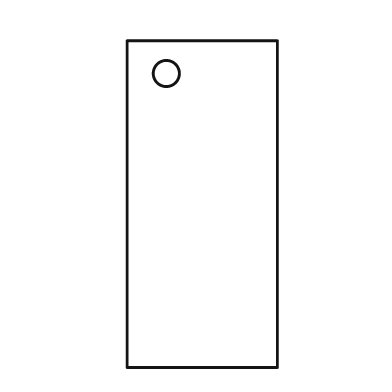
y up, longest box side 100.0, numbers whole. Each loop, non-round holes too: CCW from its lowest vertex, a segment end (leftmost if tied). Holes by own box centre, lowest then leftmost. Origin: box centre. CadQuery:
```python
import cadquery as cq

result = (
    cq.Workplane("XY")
    .moveTo(-23.0, -50.0)
    .lineTo(23.0, -50.0)
    .lineTo(23.0, 50.0)
    .lineTo(-23.0, 50.0)
    .close()
    .moveTo(-11.0, 40.0)
    .circle(4.0)
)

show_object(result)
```